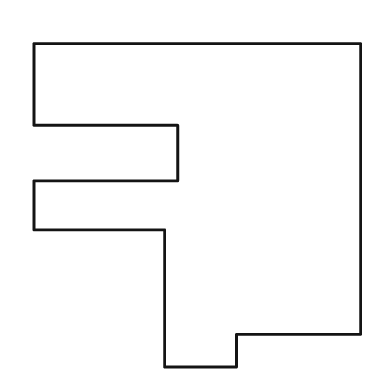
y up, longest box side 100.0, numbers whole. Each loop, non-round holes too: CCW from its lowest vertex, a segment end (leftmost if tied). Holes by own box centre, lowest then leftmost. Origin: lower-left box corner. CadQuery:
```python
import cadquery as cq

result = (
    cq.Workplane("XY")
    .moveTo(40.0, 0.0)
    .lineTo(62.0, 0.0)
    .lineTo(62.0, 10.0)
    .lineTo(100.0, 10.0)
    .lineTo(100.0, 99.0)
    .lineTo(0.0, 99.0)
    .lineTo(0.0, 74.0)
    .lineTo(44.0, 74.0)
    .lineTo(44.0, 57.0)
    .lineTo(0.0, 57.0)
    .lineTo(0.0, 42.0)
    .lineTo(40.0, 42.0)
    .close()
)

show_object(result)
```